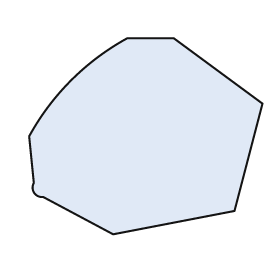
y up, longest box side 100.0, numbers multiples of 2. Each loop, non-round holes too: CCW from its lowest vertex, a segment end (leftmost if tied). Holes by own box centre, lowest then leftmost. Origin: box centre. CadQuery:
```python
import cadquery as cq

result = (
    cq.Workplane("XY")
    .moveTo(-14.0, -42.0)
    .lineTo(38.0, -32.0)
    .lineTo(50.0, 14.0)
    .lineTo(12.0, 42.0)
    .lineTo(-8.0, 42.0)
    .threePointArc((-32.0, 24.0), (-50.0, 0.0))
    .lineTo(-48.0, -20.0)
    .threePointArc((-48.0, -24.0), (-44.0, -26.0))
    .close()
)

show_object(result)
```